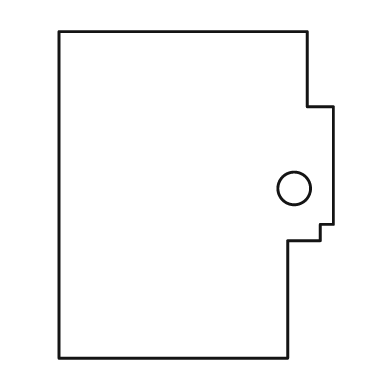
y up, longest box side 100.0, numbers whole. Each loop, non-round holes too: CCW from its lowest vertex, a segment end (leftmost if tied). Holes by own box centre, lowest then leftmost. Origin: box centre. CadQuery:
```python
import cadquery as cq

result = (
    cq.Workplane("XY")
    .moveTo(-42.0, -50.0)
    .lineTo(28.0, -50.0)
    .lineTo(28.0, -14.0)
    .lineTo(38.0, -14.0)
    .lineTo(38.0, -9.0)
    .lineTo(42.0, -9.0)
    .lineTo(42.0, 27.0)
    .lineTo(34.0, 27.0)
    .lineTo(34.0, 50.0)
    .lineTo(-42.0, 50.0)
    .close()
    .moveTo(30.0, 2.0)
    .circle(5.0)
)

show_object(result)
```